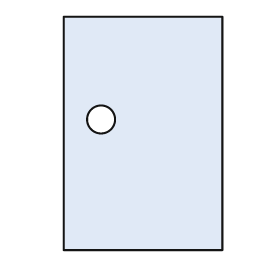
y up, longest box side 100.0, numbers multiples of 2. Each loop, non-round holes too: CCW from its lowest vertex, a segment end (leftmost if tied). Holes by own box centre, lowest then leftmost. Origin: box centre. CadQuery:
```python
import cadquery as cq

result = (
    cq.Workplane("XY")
    .moveTo(-34.0, -50.0)
    .lineTo(34.0, -50.0)
    .lineTo(34.0, 50.0)
    .lineTo(-34.0, 50.0)
    .close()
    .moveTo(-18.0, 6.0)
    .circle(6.0)
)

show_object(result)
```